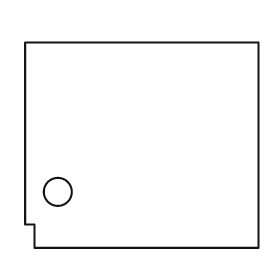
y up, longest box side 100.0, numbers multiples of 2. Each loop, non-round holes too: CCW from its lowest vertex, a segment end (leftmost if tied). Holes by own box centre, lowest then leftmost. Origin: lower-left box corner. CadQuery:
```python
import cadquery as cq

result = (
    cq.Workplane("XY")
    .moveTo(4.0, 0.0)
    .lineTo(100.0, 0.0)
    .lineTo(100.0, 88.0)
    .lineTo(0.0, 88.0)
    .lineTo(0.0, 10.0)
    .lineTo(4.0, 10.0)
    .close()
    .moveTo(14.0, 24.0)
    .circle(6.0)
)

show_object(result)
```